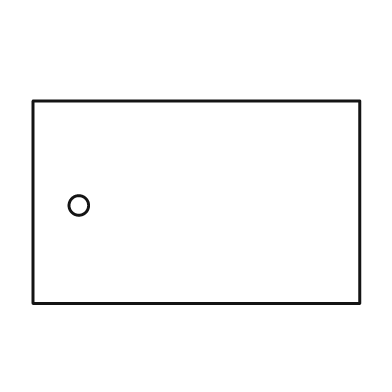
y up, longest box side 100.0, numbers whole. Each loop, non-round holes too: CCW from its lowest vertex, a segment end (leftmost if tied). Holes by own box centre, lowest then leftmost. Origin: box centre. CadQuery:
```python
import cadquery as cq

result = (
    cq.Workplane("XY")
    .moveTo(-50.0, -31.0)
    .lineTo(50.0, -31.0)
    .lineTo(50.0, 31.0)
    .lineTo(-50.0, 31.0)
    .close()
    .moveTo(-36.0, -1.0)
    .circle(3.0)
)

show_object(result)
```